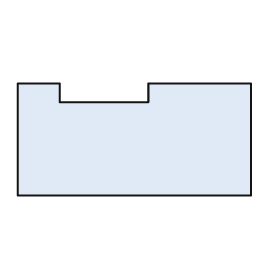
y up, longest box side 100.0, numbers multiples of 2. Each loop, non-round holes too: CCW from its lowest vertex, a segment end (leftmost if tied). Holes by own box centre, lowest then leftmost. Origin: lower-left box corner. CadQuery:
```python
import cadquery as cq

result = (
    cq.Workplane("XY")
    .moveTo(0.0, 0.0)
    .lineTo(100.0, 0.0)
    .lineTo(100.0, 48.0)
    .lineTo(56.0, 48.0)
    .lineTo(56.0, 40.0)
    .lineTo(18.0, 40.0)
    .lineTo(18.0, 48.0)
    .lineTo(0.0, 48.0)
    .close()
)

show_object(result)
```